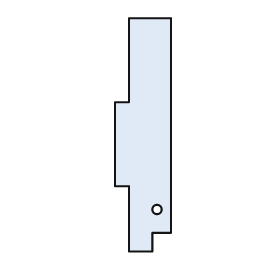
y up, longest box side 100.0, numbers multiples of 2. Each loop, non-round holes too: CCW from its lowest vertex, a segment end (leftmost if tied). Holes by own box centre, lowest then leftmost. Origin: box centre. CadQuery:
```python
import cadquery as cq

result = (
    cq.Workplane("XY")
    .moveTo(-6.0, -50.0)
    .lineTo(4.0, -50.0)
    .lineTo(4.0, -42.0)
    .lineTo(12.0, -42.0)
    .lineTo(12.0, 50.0)
    .lineTo(-6.0, 50.0)
    .lineTo(-6.0, 14.0)
    .lineTo(-12.0, 14.0)
    .lineTo(-12.0, -22.0)
    .lineTo(-6.0, -22.0)
    .close()
    .moveTo(6.0, -32.0)
    .circle(2.0)
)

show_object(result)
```